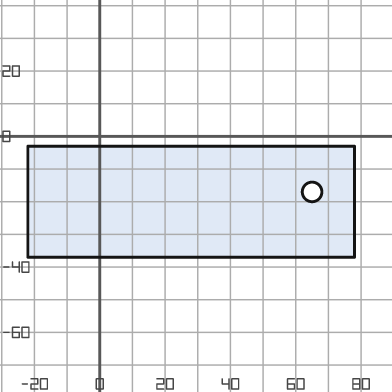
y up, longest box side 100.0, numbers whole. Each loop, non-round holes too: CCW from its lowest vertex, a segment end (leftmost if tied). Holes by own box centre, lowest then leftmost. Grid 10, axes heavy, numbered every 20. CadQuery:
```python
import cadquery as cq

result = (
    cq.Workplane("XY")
    .moveTo(-22.0, -37.0)
    .lineTo(78.0, -37.0)
    .lineTo(78.0, -3.0)
    .lineTo(-22.0, -3.0)
    .close()
    .moveTo(65.0, -17.0)
    .circle(3.0)
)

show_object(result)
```